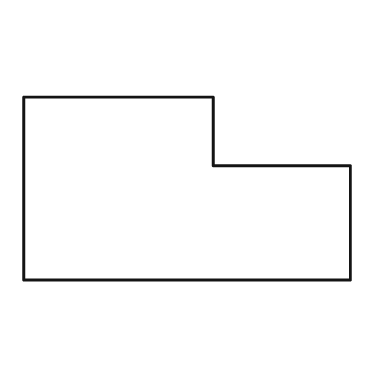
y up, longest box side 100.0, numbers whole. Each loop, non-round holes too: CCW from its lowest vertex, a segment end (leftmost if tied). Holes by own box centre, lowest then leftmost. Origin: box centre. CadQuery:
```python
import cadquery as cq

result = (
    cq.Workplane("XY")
    .moveTo(-50.0, -28.0)
    .lineTo(50.0, -28.0)
    .lineTo(50.0, 7.0)
    .lineTo(8.0, 7.0)
    .lineTo(8.0, 28.0)
    .lineTo(-50.0, 28.0)
    .close()
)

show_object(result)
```